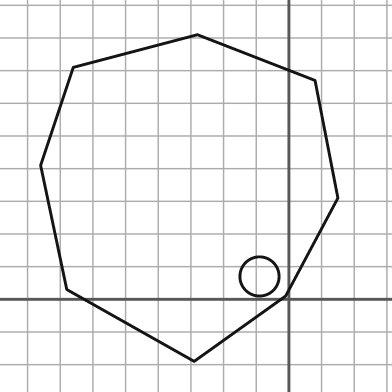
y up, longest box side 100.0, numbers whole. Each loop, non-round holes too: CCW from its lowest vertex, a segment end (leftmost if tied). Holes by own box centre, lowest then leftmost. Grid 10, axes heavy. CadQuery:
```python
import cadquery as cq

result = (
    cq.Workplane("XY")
    .moveTo(-29.0, -19.0)
    .lineTo(-1.0, 1.0)
    .lineTo(15.0, 31.0)
    .lineTo(8.0, 67.0)
    .lineTo(-28.0, 81.0)
    .lineTo(-66.0, 71.0)
    .lineTo(-76.0, 41.0)
    .lineTo(-68.0, 3.0)
    .close()
    .moveTo(-9.0, 7.0)
    .circle(6.0)
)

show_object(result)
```